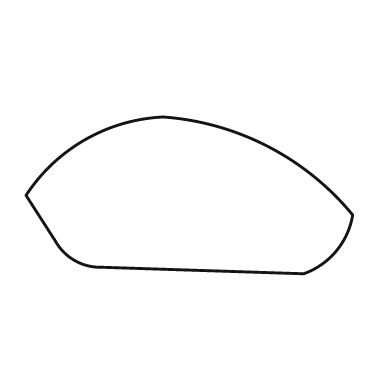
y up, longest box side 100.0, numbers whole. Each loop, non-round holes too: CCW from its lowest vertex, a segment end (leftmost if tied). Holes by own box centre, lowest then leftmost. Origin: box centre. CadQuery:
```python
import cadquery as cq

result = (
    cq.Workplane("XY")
    .moveTo(35.0, -24.0)
    .threePointArc((45.0, -17.0), (50.0, -6.0))
    .threePointArc((24.0, 15.0), (-8.0, 24.0))
    .threePointArc((-32.0, 17.0), (-50.0, 0.0))
    .lineTo(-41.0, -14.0)
    .threePointArc((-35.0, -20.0), (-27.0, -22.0))
    .close()
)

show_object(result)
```